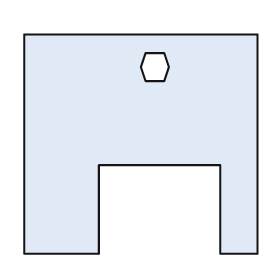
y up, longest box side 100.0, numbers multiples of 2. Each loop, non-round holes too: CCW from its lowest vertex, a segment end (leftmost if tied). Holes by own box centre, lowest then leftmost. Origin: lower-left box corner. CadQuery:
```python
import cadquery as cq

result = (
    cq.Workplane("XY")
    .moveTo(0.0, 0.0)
    .lineTo(32.0, 0.0)
    .lineTo(32.0, 38.0)
    .lineTo(84.0, 38.0)
    .lineTo(84.0, 0.0)
    .lineTo(100.0, 0.0)
    .lineTo(100.0, 94.0)
    .lineTo(0.0, 94.0)
    .close()
    .moveTo(52.0, 74.0)
    .lineTo(60.0, 74.0)
    .lineTo(62.0, 80.0)
    .lineTo(60.0, 86.0)
    .lineTo(52.0, 86.0)
    .lineTo(50.0, 80.0)
    .close()
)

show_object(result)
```